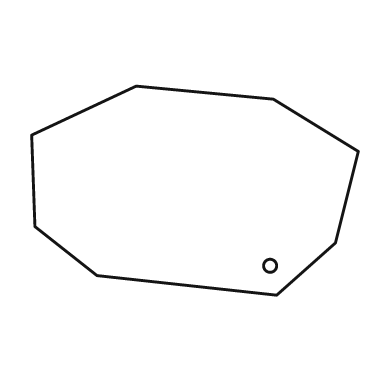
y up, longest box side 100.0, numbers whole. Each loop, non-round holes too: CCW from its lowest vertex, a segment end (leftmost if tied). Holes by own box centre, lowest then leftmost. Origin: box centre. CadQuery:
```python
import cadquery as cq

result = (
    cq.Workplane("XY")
    .moveTo(25.0, -32.0)
    .lineTo(43.0, -16.0)
    .lineTo(50.0, 12.0)
    .lineTo(24.0, 28.0)
    .lineTo(-18.0, 32.0)
    .lineTo(-50.0, 17.0)
    .lineTo(-49.0, -11.0)
    .lineTo(-30.0, -26.0)
    .close()
    .moveTo(23.0, -23.0)
    .circle(2.0)
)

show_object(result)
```